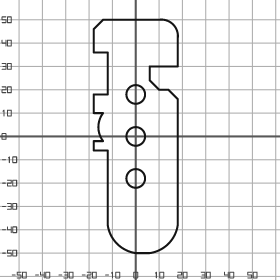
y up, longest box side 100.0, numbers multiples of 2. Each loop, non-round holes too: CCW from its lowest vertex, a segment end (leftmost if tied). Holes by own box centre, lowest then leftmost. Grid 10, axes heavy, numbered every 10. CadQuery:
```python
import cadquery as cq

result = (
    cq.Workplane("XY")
    .moveTo(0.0, -50.0)
    .lineTo(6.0, -50.0)
    .threePointArc((14.0, -46.0), (18.0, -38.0))
    .lineTo(18.0, 16.0)
    .lineTo(14.0, 20.0)
    .lineTo(10.0, 20.0)
    .lineTo(6.0, 24.0)
    .lineTo(6.0, 30.0)
    .lineTo(18.0, 30.0)
    .lineTo(18.0, 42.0)
    .threePointArc((16.0, 48.0), (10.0, 50.0))
    .lineTo(-14.0, 50.0)
    .lineTo(-18.0, 46.0)
    .lineTo(-18.0, 36.0)
    .lineTo(-12.0, 36.0)
    .lineTo(-12.0, 18.0)
    .lineTo(-18.0, 18.0)
    .lineTo(-18.0, 10.0)
    .lineTo(-14.0, 10.0)
    .threePointArc((-16.0, 4.0), (-14.0, -2.0))
    .lineTo(-18.0, -2.0)
    .lineTo(-18.0, -6.0)
    .lineTo(-12.0, -6.0)
    .lineTo(-12.0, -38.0)
    .threePointArc((-8.0, -46.0), (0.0, -50.0))
    .close()
    .moveTo(0.0, -18.0)
    .circle(4.0)
    .moveTo(0.0, 0.0)
    .circle(4.0)
    .moveTo(0.0, 18.0)
    .circle(4.0)
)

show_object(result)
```